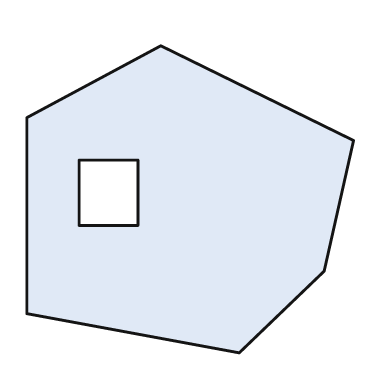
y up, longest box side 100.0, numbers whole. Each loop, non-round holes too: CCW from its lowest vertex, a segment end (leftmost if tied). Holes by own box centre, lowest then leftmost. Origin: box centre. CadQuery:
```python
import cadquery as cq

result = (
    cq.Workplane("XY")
    .moveTo(15.0, -47.0)
    .lineTo(41.0, -22.0)
    .lineTo(50.0, 18.0)
    .lineTo(-9.0, 47.0)
    .lineTo(-50.0, 25.0)
    .lineTo(-50.0, -35.0)
    .close()
    .moveTo(-34.0, -8.0)
    .lineTo(-16.0, -8.0)
    .lineTo(-16.0, 12.0)
    .lineTo(-34.0, 12.0)
    .close()
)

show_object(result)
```